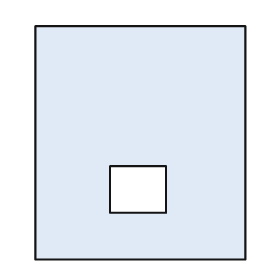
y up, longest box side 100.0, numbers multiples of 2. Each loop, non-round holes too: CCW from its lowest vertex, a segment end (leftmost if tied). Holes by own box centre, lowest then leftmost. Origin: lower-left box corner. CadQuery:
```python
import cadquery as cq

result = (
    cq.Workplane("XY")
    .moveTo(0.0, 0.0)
    .lineTo(90.0, 0.0)
    .lineTo(90.0, 100.0)
    .lineTo(0.0, 100.0)
    .close()
    .moveTo(32.0, 20.0)
    .lineTo(56.0, 20.0)
    .lineTo(56.0, 40.0)
    .lineTo(32.0, 40.0)
    .close()
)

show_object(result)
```